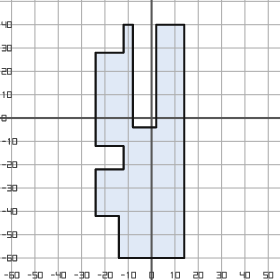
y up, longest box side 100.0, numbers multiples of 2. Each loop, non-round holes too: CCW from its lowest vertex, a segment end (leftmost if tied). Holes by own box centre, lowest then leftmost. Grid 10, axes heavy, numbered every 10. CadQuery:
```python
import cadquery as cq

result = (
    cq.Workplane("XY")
    .moveTo(-14.0, -60.0)
    .lineTo(14.0, -60.0)
    .lineTo(14.0, 40.0)
    .lineTo(2.0, 40.0)
    .lineTo(2.0, -4.0)
    .lineTo(-8.0, -4.0)
    .lineTo(-8.0, 40.0)
    .lineTo(-12.0, 40.0)
    .lineTo(-12.0, 28.0)
    .lineTo(-24.0, 28.0)
    .lineTo(-24.0, -12.0)
    .lineTo(-12.0, -12.0)
    .lineTo(-12.0, -22.0)
    .lineTo(-24.0, -22.0)
    .lineTo(-24.0, -42.0)
    .lineTo(-14.0, -42.0)
    .close()
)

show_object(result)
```